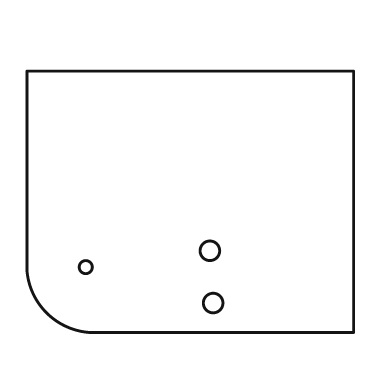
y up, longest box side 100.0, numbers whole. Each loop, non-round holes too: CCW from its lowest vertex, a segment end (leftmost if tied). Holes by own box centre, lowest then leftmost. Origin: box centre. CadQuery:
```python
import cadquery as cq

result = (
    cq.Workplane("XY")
    .moveTo(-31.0, -40.0)
    .lineTo(50.0, -40.0)
    .lineTo(50.0, 40.0)
    .lineTo(-50.0, 40.0)
    .lineTo(-50.0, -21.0)
    .threePointArc((-44.0, -34.0), (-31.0, -40.0))
    .close()
    .moveTo(7.0, -31.0)
    .circle(3.0)
    .moveTo(-32.0, -20.0)
    .circle(2.0)
    .moveTo(6.0, -15.0)
    .circle(3.0)
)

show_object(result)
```